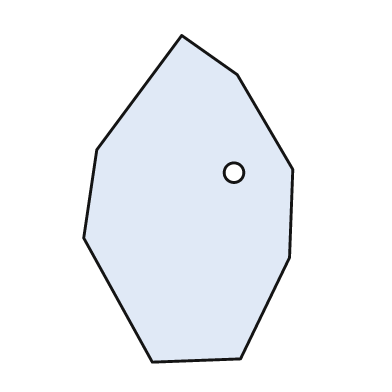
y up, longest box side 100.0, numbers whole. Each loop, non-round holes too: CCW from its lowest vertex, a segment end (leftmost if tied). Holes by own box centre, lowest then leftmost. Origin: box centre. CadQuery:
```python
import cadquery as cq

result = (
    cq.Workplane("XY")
    .moveTo(-11.0, -50.0)
    .lineTo(16.0, -49.0)
    .lineTo(31.0, -18.0)
    .lineTo(32.0, 9.0)
    .lineTo(15.0, 38.0)
    .lineTo(-2.0, 50.0)
    .lineTo(-28.0, 15.0)
    .lineTo(-32.0, -12.0)
    .close()
    .moveTo(14.0, 8.0)
    .circle(3.0)
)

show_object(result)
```